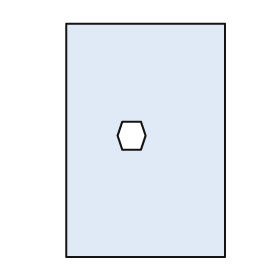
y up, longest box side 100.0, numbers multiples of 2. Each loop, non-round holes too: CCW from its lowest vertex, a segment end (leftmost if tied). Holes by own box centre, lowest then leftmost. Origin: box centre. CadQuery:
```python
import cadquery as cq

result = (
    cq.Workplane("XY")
    .moveTo(-34.0, -50.0)
    .lineTo(34.0, -50.0)
    .lineTo(34.0, 50.0)
    .lineTo(-34.0, 50.0)
    .close()
    .moveTo(-10.0, -4.0)
    .lineTo(-2.0, -4.0)
    .lineTo(0.0, 2.0)
    .lineTo(-2.0, 8.0)
    .lineTo(-10.0, 8.0)
    .lineTo(-12.0, 2.0)
    .close()
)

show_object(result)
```